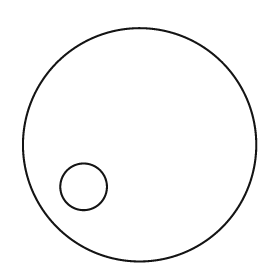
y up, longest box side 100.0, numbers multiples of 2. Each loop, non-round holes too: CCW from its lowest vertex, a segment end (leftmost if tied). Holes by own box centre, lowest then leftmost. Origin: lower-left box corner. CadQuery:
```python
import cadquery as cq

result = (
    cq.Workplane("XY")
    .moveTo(50.0, 50.0)
    .circle(50.0)
    .moveTo(26.0, 32.0)
    .circle(10.0)
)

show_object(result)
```